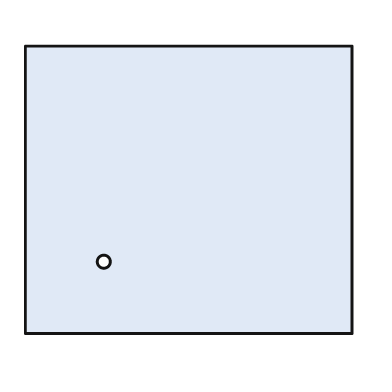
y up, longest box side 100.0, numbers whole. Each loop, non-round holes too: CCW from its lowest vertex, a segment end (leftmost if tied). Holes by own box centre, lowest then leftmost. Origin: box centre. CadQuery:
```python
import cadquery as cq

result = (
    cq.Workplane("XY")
    .moveTo(-50.0, -44.0)
    .lineTo(50.0, -44.0)
    .lineTo(50.0, 44.0)
    .lineTo(-50.0, 44.0)
    .close()
    .moveTo(-26.0, -22.0)
    .circle(2.0)
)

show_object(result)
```